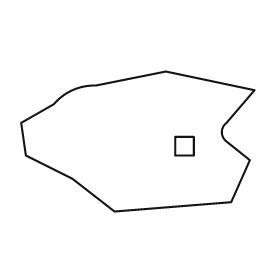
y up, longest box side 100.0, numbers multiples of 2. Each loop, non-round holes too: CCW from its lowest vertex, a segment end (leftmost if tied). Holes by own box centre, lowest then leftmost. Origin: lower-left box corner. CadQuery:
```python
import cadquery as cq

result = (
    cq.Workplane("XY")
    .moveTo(40.0, 0.0)
    .lineTo(90.0, 4.0)
    .lineTo(98.0, 22.0)
    .lineTo(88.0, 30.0)
    .threePointArc((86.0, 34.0), (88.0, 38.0))
    .lineTo(100.0, 52.0)
    .lineTo(62.0, 60.0)
    .lineTo(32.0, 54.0)
    .threePointArc((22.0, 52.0), (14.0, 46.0))
    .lineTo(0.0, 38.0)
    .lineTo(2.0, 24.0)
    .lineTo(22.0, 14.0)
    .close()
    .moveTo(66.0, 24.0)
    .lineTo(74.0, 24.0)
    .lineTo(74.0, 32.0)
    .lineTo(66.0, 32.0)
    .close()
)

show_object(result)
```